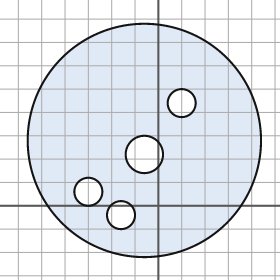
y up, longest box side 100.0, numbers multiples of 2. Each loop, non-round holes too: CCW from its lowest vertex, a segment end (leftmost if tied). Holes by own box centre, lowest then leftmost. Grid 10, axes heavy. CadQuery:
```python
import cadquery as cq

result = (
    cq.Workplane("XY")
    .moveTo(-6.0, 28.0)
    .circle(50.0)
    .moveTo(-16.0, -4.0)
    .circle(6.0)
    .moveTo(-30.0, 6.0)
    .circle(6.0)
    .moveTo(-6.0, 22.0)
    .circle(8.0)
    .moveTo(10.0, 44.0)
    .circle(6.0)
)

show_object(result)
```